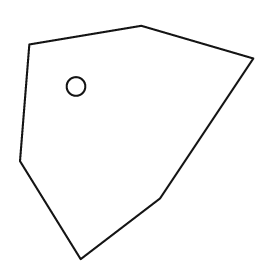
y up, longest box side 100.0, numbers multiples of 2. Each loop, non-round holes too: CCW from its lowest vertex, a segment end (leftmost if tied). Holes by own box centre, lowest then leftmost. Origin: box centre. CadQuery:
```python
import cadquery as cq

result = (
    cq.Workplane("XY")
    .moveTo(-24.0, -50.0)
    .lineTo(10.0, -24.0)
    .lineTo(50.0, 36.0)
    .lineTo(2.0, 50.0)
    .lineTo(-46.0, 42.0)
    .lineTo(-50.0, -8.0)
    .close()
    .moveTo(-26.0, 24.0)
    .circle(4.0)
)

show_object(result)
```